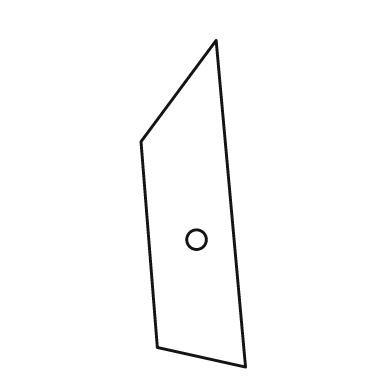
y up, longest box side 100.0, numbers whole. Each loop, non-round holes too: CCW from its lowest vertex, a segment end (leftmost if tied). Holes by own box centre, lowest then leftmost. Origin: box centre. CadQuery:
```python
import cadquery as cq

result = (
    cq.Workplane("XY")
    .moveTo(16.0, -50.0)
    .lineTo(7.0, 50.0)
    .lineTo(-16.0, 19.0)
    .lineTo(-11.0, -44.0)
    .close()
    .moveTo(1.0, -11.0)
    .circle(3.0)
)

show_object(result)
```